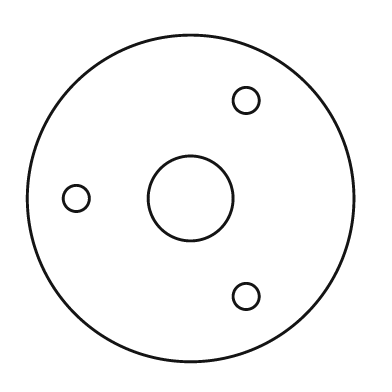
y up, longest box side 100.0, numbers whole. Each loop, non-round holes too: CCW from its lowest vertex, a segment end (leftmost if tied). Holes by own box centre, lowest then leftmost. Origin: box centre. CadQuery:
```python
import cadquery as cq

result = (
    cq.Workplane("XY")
    .moveTo(0.0, 0.0)
    .circle(50.0)
    .moveTo(17.0, -30.0)
    .circle(4.0)
    .moveTo(-35.0, 0.0)
    .circle(4.0)
    .moveTo(0.0, 0.0)
    .circle(13.0)
    .moveTo(17.0, 30.0)
    .circle(4.0)
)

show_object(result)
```